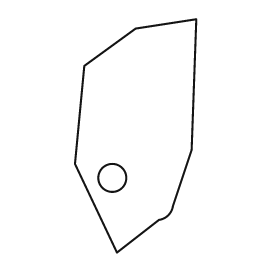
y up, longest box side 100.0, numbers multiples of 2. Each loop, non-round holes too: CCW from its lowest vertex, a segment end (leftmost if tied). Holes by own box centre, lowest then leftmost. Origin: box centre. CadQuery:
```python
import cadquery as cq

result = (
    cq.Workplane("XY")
    .moveTo(-8.0, -50.0)
    .lineTo(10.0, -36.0)
    .threePointArc((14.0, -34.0), (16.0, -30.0))
    .lineTo(24.0, -6.0)
    .lineTo(26.0, 50.0)
    .lineTo(0.0, 46.0)
    .lineTo(-22.0, 30.0)
    .lineTo(-26.0, -12.0)
    .close()
    .moveTo(-10.0, -18.0)
    .circle(6.0)
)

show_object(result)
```